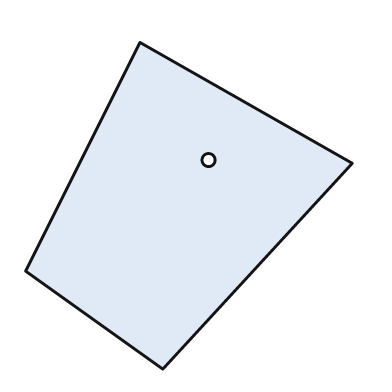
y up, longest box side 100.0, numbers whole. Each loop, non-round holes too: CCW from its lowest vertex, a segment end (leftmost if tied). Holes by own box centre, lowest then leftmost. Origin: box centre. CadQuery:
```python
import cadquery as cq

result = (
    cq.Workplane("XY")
    .moveTo(-8.0, -50.0)
    .lineTo(50.0, 13.0)
    .lineTo(-15.0, 50.0)
    .lineTo(-50.0, -20.0)
    .close()
    .moveTo(6.0, 14.0)
    .circle(2.0)
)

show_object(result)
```